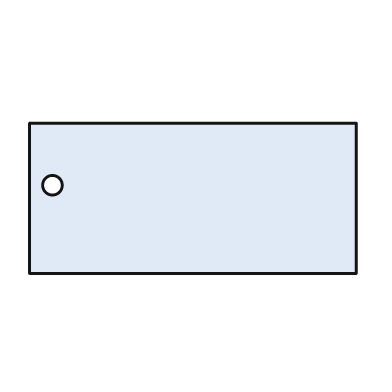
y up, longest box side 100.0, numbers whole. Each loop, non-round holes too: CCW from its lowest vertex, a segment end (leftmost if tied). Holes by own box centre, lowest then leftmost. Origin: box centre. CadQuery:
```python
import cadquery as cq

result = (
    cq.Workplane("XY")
    .moveTo(-50.0, -23.0)
    .lineTo(50.0, -23.0)
    .lineTo(50.0, 23.0)
    .lineTo(-50.0, 23.0)
    .close()
    .moveTo(-43.0, 4.0)
    .circle(3.0)
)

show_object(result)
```